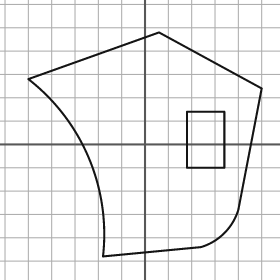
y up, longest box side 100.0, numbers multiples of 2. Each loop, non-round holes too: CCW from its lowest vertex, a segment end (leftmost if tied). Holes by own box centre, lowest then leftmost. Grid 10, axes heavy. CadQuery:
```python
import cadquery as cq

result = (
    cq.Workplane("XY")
    .moveTo(-18.0, -48.0)
    .lineTo(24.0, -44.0)
    .threePointArc((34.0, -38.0), (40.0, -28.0))
    .lineTo(50.0, 24.0)
    .lineTo(6.0, 48.0)
    .lineTo(-50.0, 28.0)
    .threePointArc((-24.0, -6.0), (-18.0, -48.0))
    .close()
    .moveTo(18.0, -10.0)
    .lineTo(34.0, -10.0)
    .lineTo(34.0, 14.0)
    .lineTo(18.0, 14.0)
    .close()
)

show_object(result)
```